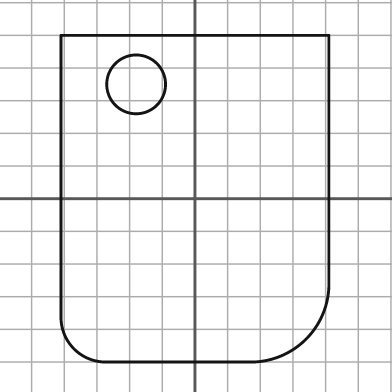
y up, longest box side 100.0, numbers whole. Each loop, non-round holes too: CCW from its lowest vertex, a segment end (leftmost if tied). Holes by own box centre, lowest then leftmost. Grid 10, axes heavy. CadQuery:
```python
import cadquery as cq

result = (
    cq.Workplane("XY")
    .moveTo(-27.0, -50.0)
    .lineTo(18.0, -50.0)
    .threePointArc((34.0, -43.0), (41.0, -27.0))
    .lineTo(41.0, 50.0)
    .lineTo(-41.0, 50.0)
    .lineTo(-41.0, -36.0)
    .threePointArc((-37.0, -46.0), (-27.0, -50.0))
    .close()
    .moveTo(-18.0, 35.0)
    .circle(9.0)
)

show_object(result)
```